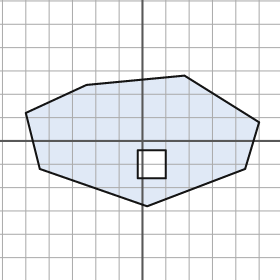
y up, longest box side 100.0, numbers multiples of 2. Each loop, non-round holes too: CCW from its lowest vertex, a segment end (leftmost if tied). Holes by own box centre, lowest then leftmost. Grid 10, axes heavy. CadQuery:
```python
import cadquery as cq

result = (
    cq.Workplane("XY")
    .moveTo(2.0, -28.0)
    .lineTo(44.0, -12.0)
    .lineTo(50.0, 8.0)
    .lineTo(18.0, 28.0)
    .lineTo(-24.0, 24.0)
    .lineTo(-50.0, 12.0)
    .lineTo(-44.0, -12.0)
    .close()
    .moveTo(-2.0, -16.0)
    .lineTo(10.0, -16.0)
    .lineTo(10.0, -4.0)
    .lineTo(-2.0, -4.0)
    .close()
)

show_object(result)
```